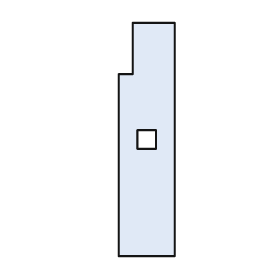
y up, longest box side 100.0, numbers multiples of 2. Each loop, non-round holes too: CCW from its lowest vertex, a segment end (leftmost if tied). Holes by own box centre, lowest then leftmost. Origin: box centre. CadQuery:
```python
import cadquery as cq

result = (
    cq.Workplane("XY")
    .moveTo(-12.0, -50.0)
    .lineTo(12.0, -50.0)
    .lineTo(12.0, 50.0)
    .lineTo(-6.0, 50.0)
    .lineTo(-6.0, 28.0)
    .lineTo(-12.0, 28.0)
    .close()
    .moveTo(-4.0, -4.0)
    .lineTo(4.0, -4.0)
    .lineTo(4.0, 4.0)
    .lineTo(-4.0, 4.0)
    .close()
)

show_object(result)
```